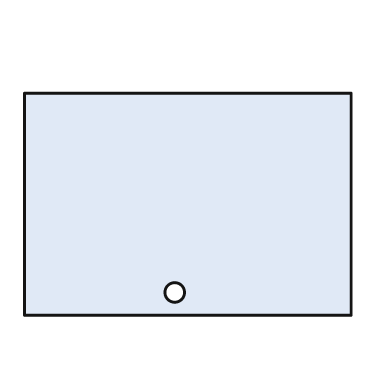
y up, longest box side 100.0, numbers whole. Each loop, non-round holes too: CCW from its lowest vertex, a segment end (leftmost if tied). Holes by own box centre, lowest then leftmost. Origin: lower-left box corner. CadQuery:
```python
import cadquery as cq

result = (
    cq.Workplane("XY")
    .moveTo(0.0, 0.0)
    .lineTo(100.0, 0.0)
    .lineTo(100.0, 68.0)
    .lineTo(0.0, 68.0)
    .close()
    .moveTo(46.0, 7.0)
    .circle(3.0)
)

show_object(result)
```